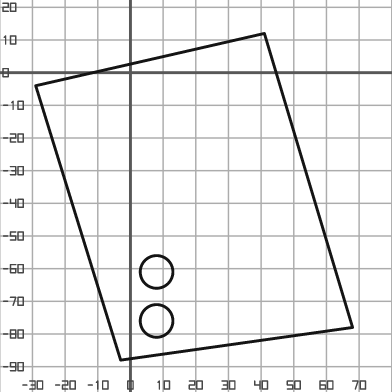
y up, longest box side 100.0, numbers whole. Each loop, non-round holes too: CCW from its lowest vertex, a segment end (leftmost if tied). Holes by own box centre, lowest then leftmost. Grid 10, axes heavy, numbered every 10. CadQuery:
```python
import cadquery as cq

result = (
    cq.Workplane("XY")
    .moveTo(-3.0, -88.0)
    .lineTo(68.0, -78.0)
    .lineTo(41.0, 12.0)
    .lineTo(-29.0, -4.0)
    .close()
    .moveTo(8.0, -76.0)
    .circle(5.0)
    .moveTo(8.0, -61.0)
    .circle(5.0)
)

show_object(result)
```